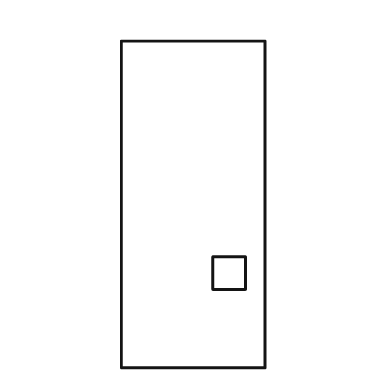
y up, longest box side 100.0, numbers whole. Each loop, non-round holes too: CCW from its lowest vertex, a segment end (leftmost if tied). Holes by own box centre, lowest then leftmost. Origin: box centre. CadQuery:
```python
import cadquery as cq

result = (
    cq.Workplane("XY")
    .moveTo(-22.0, -50.0)
    .lineTo(22.0, -50.0)
    .lineTo(22.0, 50.0)
    .lineTo(-22.0, 50.0)
    .close()
    .moveTo(6.0, -26.0)
    .lineTo(16.0, -26.0)
    .lineTo(16.0, -16.0)
    .lineTo(6.0, -16.0)
    .close()
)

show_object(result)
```